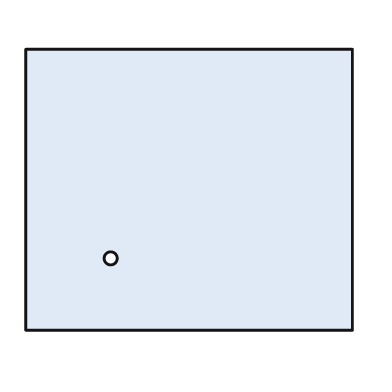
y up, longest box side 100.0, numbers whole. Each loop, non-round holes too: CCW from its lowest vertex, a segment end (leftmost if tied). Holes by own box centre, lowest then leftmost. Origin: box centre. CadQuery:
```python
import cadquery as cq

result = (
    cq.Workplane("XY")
    .moveTo(-50.0, -43.0)
    .lineTo(50.0, -43.0)
    .lineTo(50.0, 43.0)
    .lineTo(-50.0, 43.0)
    .close()
    .moveTo(-24.0, -21.0)
    .circle(2.0)
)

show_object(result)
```